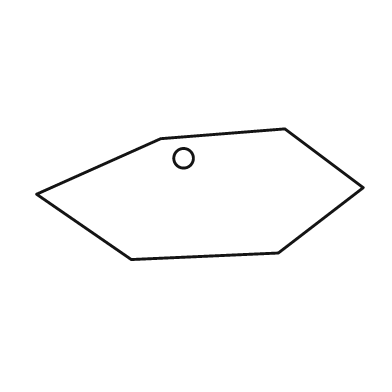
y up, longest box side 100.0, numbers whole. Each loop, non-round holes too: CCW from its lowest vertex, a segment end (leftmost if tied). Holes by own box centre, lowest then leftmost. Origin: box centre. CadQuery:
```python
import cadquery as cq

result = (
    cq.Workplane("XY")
    .moveTo(-21.0, -20.0)
    .lineTo(24.0, -18.0)
    .lineTo(50.0, 2.0)
    .lineTo(26.0, 20.0)
    .lineTo(-12.0, 17.0)
    .lineTo(-50.0, 0.0)
    .close()
    .moveTo(-5.0, 11.0)
    .circle(3.0)
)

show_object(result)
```